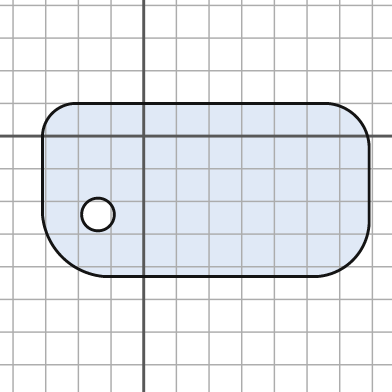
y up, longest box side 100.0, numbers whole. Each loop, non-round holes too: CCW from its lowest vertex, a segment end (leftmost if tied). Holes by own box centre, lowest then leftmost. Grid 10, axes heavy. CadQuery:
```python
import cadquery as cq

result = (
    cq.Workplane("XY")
    .moveTo(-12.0, -43.0)
    .lineTo(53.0, -43.0)
    .threePointArc((64.0, -38.0), (69.0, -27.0))
    .lineTo(69.0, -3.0)
    .threePointArc((65.0, 6.0), (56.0, 10.0))
    .lineTo(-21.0, 10.0)
    .threePointArc((-28.0, 7.0), (-31.0, 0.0))
    .lineTo(-31.0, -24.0)
    .threePointArc((-25.0, -37.0), (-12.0, -43.0))
    .close()
    .moveTo(-14.0, -24.0)
    .circle(5.0)
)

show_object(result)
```